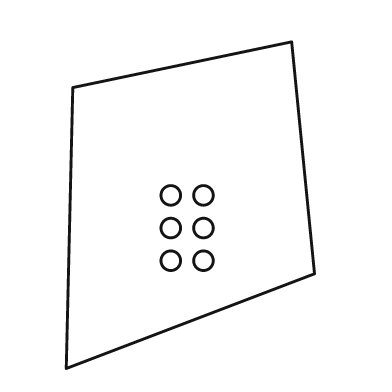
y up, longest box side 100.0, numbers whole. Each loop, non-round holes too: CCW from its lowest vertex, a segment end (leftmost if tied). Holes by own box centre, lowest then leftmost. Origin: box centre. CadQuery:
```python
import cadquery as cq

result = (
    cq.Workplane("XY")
    .moveTo(-38.0, -50.0)
    .lineTo(38.0, -21.0)
    .lineTo(31.0, 50.0)
    .lineTo(-36.0, 36.0)
    .close()
    .moveTo(-6.0, -17.0)
    .circle(3.0)
    .moveTo(4.0, -17.0)
    .circle(3.0)
    .moveTo(-6.0, -7.0)
    .circle(3.0)
    .moveTo(4.0, -7.0)
    .circle(3.0)
    .moveTo(-6.0, 3.0)
    .circle(3.0)
    .moveTo(4.0, 3.0)
    .circle(3.0)
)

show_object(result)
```